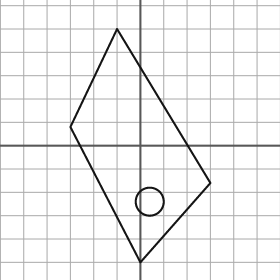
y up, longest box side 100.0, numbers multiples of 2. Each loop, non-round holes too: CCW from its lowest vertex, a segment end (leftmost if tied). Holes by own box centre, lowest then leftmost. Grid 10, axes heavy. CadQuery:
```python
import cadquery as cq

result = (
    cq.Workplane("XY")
    .moveTo(0.0, -50.0)
    .lineTo(30.0, -16.0)
    .lineTo(-10.0, 50.0)
    .lineTo(-30.0, 8.0)
    .close()
    .moveTo(4.0, -24.0)
    .circle(6.0)
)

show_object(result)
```